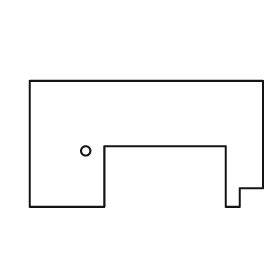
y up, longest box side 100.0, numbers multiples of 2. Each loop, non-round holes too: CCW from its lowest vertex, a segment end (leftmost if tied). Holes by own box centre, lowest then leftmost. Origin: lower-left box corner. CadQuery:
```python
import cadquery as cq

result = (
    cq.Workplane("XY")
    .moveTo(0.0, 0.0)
    .lineTo(32.0, 0.0)
    .lineTo(32.0, 26.0)
    .lineTo(84.0, 26.0)
    .lineTo(84.0, 0.0)
    .lineTo(90.0, 0.0)
    .lineTo(90.0, 8.0)
    .lineTo(100.0, 8.0)
    .lineTo(100.0, 54.0)
    .lineTo(0.0, 54.0)
    .close()
    .moveTo(24.0, 24.0)
    .circle(2.0)
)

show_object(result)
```